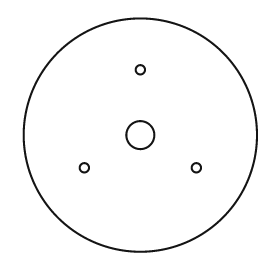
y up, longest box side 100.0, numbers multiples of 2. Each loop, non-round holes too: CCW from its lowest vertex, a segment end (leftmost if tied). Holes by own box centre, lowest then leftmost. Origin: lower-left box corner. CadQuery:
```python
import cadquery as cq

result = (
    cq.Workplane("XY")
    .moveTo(50.0, 50.0)
    .circle(50.0)
    .moveTo(26.0, 36.0)
    .circle(2.0)
    .moveTo(74.0, 36.0)
    .circle(2.0)
    .moveTo(50.0, 50.0)
    .circle(6.0)
    .moveTo(50.0, 78.0)
    .circle(2.0)
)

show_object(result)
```